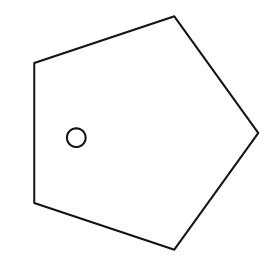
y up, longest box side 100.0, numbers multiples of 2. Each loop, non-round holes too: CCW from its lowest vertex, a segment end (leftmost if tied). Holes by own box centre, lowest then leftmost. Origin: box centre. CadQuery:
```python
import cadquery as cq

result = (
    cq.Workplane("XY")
    .moveTo(12.0, -50.0)
    .lineTo(48.0, 0.0)
    .lineTo(12.0, 50.0)
    .lineTo(-48.0, 30.0)
    .lineTo(-48.0, -30.0)
    .close()
    .moveTo(-30.0, -2.0)
    .circle(4.0)
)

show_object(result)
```